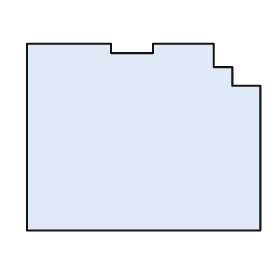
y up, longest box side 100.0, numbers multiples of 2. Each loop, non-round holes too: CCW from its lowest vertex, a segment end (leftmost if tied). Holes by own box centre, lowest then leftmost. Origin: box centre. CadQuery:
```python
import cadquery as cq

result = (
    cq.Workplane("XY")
    .moveTo(-50.0, -40.0)
    .lineTo(50.0, -40.0)
    .lineTo(50.0, 22.0)
    .lineTo(38.0, 22.0)
    .lineTo(38.0, 30.0)
    .lineTo(30.0, 30.0)
    .lineTo(30.0, 40.0)
    .lineTo(4.0, 40.0)
    .lineTo(4.0, 36.0)
    .lineTo(-14.0, 36.0)
    .lineTo(-14.0, 40.0)
    .lineTo(-50.0, 40.0)
    .close()
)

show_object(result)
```